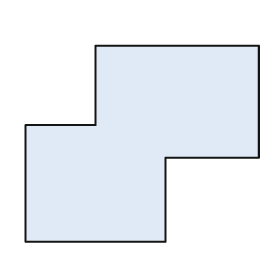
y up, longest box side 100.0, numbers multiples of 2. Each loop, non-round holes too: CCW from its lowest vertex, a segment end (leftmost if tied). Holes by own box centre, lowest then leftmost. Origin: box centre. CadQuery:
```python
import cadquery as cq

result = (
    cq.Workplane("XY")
    .moveTo(-50.0, -42.0)
    .lineTo(10.0, -42.0)
    .lineTo(10.0, -6.0)
    .lineTo(50.0, -6.0)
    .lineTo(50.0, 42.0)
    .lineTo(-20.0, 42.0)
    .lineTo(-20.0, 8.0)
    .lineTo(-50.0, 8.0)
    .close()
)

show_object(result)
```